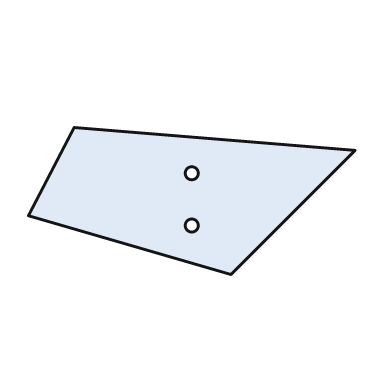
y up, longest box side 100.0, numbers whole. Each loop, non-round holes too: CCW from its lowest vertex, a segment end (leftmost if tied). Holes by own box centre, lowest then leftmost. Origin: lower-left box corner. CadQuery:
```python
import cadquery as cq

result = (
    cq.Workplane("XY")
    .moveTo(62.0, 0.0)
    .lineTo(100.0, 38.0)
    .lineTo(14.0, 45.0)
    .lineTo(0.0, 18.0)
    .close()
    .moveTo(50.0, 15.0)
    .circle(2.0)
    .moveTo(50.0, 31.0)
    .circle(2.0)
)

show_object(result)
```